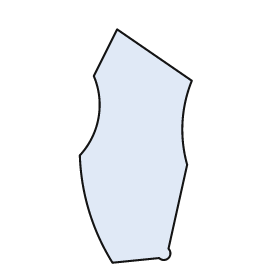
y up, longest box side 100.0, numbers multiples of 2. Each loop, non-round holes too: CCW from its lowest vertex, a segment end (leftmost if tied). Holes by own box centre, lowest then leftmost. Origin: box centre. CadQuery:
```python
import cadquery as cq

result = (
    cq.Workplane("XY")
    .moveTo(-10.0, -50.0)
    .lineTo(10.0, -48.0)
    .threePointArc((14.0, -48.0), (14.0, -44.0))
    .lineTo(22.0, -8.0)
    .threePointArc((20.0, 10.0), (24.0, 28.0))
    .lineTo(-8.0, 50.0)
    .lineTo(-18.0, 30.0)
    .threePointArc((-16.0, 12.0), (-24.0, -4.0))
    .threePointArc((-20.0, -28.0), (-10.0, -50.0))
    .close()
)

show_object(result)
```